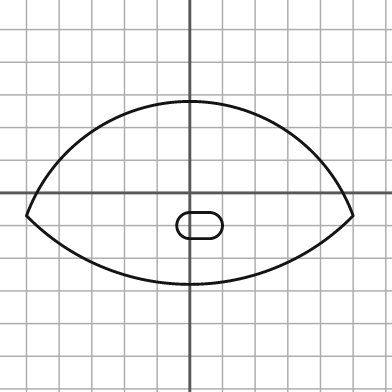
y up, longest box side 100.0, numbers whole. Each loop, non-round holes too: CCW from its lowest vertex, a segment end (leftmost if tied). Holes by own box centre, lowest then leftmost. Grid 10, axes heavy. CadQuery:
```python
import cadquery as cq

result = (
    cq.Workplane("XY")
    .moveTo(-50.0, -7.0)
    .threePointArc((0.0, -28.0), (50.0, -7.0))
    .threePointArc((0.0, 28.0), (-50.0, -7.0))
    .close()
    .moveTo(0.0, -14.0)
    .lineTo(6.0, -14.0)
    .threePointArc((10.0, -10.0), (6.0, -6.0))
    .lineTo(0.0, -6.0)
    .threePointArc((-4.0, -10.0), (0.0, -14.0))
    .close()
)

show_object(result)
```